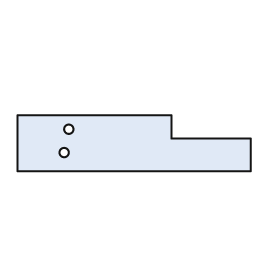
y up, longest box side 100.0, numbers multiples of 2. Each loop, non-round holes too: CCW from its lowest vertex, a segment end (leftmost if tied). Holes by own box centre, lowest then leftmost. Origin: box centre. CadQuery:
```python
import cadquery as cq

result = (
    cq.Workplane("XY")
    .moveTo(-50.0, -12.0)
    .lineTo(50.0, -12.0)
    .lineTo(50.0, 2.0)
    .lineTo(16.0, 2.0)
    .lineTo(16.0, 12.0)
    .lineTo(-50.0, 12.0)
    .close()
    .moveTo(-30.0, -4.0)
    .circle(2.0)
    .moveTo(-28.0, 6.0)
    .circle(2.0)
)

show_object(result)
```